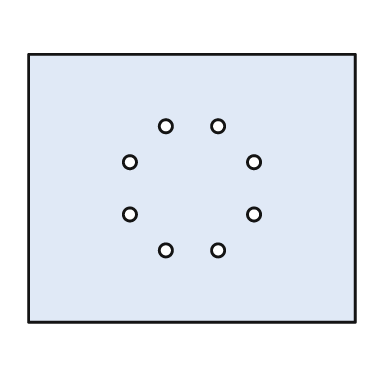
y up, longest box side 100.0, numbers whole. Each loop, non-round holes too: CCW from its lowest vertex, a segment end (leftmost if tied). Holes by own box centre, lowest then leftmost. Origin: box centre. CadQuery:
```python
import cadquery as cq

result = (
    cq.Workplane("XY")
    .moveTo(-50.0, -41.0)
    .lineTo(50.0, -41.0)
    .lineTo(50.0, 41.0)
    .lineTo(-50.0, 41.0)
    .close()
    .moveTo(-8.0, -19.0)
    .circle(2.0)
    .moveTo(8.0, -19.0)
    .circle(2.0)
    .moveTo(-19.0, -8.0)
    .circle(2.0)
    .moveTo(19.0, -8.0)
    .circle(2.0)
    .moveTo(-19.0, 8.0)
    .circle(2.0)
    .moveTo(19.0, 8.0)
    .circle(2.0)
    .moveTo(-8.0, 19.0)
    .circle(2.0)
    .moveTo(8.0, 19.0)
    .circle(2.0)
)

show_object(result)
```